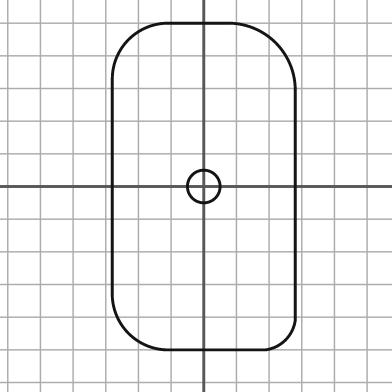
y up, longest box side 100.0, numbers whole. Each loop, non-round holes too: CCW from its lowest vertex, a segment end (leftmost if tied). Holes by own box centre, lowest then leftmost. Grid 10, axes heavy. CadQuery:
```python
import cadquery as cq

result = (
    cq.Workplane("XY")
    .moveTo(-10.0, -50.0)
    .lineTo(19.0, -50.0)
    .threePointArc((25.0, -47.0), (28.0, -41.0))
    .lineTo(28.0, 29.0)
    .threePointArc((22.0, 44.0), (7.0, 50.0))
    .lineTo(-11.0, 50.0)
    .threePointArc((-23.0, 45.0), (-28.0, 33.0))
    .lineTo(-28.0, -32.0)
    .threePointArc((-23.0, -45.0), (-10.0, -50.0))
    .close()
    .moveTo(0.0, 0.0)
    .circle(5.0)
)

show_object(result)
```